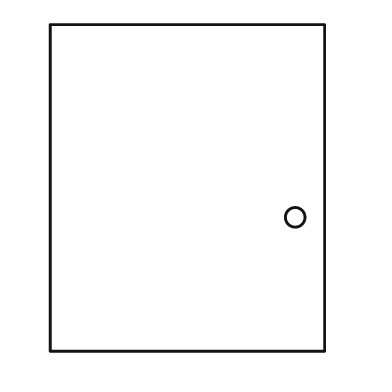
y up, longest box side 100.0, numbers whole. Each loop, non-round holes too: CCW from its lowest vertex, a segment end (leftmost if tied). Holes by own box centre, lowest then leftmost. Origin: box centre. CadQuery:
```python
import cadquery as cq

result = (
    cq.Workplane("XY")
    .moveTo(-42.0, -50.0)
    .lineTo(42.0, -50.0)
    .lineTo(42.0, 50.0)
    .lineTo(-42.0, 50.0)
    .close()
    .moveTo(33.0, -9.0)
    .circle(3.0)
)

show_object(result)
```